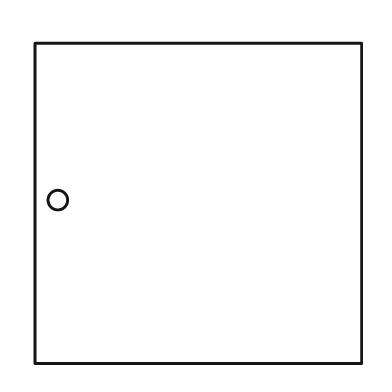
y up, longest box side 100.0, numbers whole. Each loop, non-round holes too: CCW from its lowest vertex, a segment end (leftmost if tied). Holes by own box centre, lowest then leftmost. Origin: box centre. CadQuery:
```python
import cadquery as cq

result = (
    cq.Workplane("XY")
    .moveTo(-50.0, -49.0)
    .lineTo(50.0, -49.0)
    .lineTo(50.0, 49.0)
    .lineTo(-50.0, 49.0)
    .close()
    .moveTo(-43.0, 1.0)
    .circle(3.0)
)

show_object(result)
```